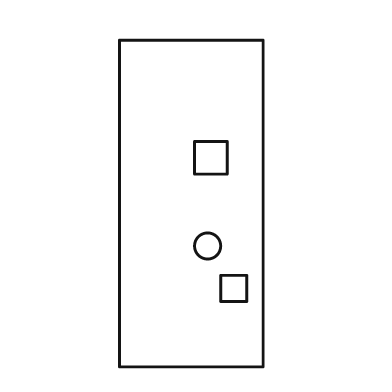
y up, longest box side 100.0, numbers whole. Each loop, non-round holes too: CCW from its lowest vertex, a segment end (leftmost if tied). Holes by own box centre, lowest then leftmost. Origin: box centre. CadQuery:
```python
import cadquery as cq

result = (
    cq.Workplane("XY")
    .moveTo(-22.0, -50.0)
    .lineTo(22.0, -50.0)
    .lineTo(22.0, 50.0)
    .lineTo(-22.0, 50.0)
    .close()
    .moveTo(9.0, -30.0)
    .lineTo(17.0, -30.0)
    .lineTo(17.0, -22.0)
    .lineTo(9.0, -22.0)
    .close()
    .moveTo(5.0, -13.0)
    .circle(4.0)
    .moveTo(1.0, 9.0)
    .lineTo(11.0, 9.0)
    .lineTo(11.0, 19.0)
    .lineTo(1.0, 19.0)
    .close()
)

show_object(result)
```